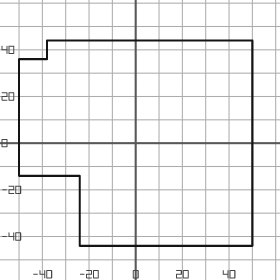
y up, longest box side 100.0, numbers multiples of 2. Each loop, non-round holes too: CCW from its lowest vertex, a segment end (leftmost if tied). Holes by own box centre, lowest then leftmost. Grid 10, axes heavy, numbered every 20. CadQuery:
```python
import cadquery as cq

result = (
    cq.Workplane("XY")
    .moveTo(-24.0, -44.0)
    .lineTo(50.0, -44.0)
    .lineTo(50.0, 44.0)
    .lineTo(-38.0, 44.0)
    .lineTo(-38.0, 36.0)
    .lineTo(-50.0, 36.0)
    .lineTo(-50.0, -14.0)
    .lineTo(-24.0, -14.0)
    .close()
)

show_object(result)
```